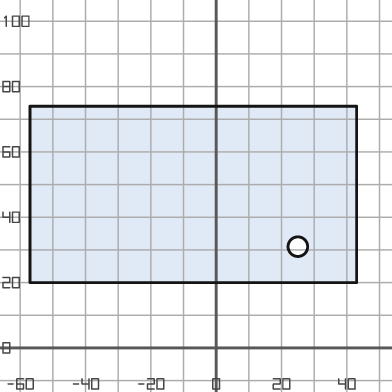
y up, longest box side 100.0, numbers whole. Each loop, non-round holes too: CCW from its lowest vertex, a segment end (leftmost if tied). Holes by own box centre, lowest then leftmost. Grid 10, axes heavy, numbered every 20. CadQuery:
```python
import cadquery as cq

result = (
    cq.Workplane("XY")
    .moveTo(-57.0, 20.0)
    .lineTo(43.0, 20.0)
    .lineTo(43.0, 74.0)
    .lineTo(-57.0, 74.0)
    .close()
    .moveTo(25.0, 31.0)
    .circle(3.0)
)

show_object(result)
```